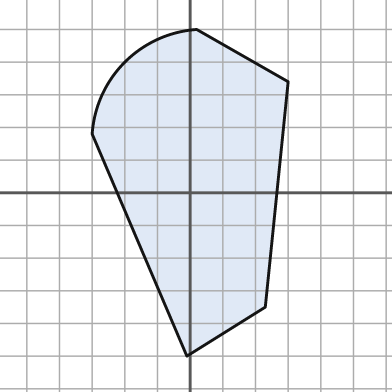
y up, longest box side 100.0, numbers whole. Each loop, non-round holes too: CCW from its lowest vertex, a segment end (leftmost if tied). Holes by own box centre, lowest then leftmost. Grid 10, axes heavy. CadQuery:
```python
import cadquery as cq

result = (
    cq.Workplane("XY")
    .moveTo(-1.0, -50.0)
    .lineTo(23.0, -35.0)
    .lineTo(30.0, 34.0)
    .lineTo(2.0, 50.0)
    .threePointArc((-20.0, 40.0), (-30.0, 18.0))
    .close()
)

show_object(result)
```